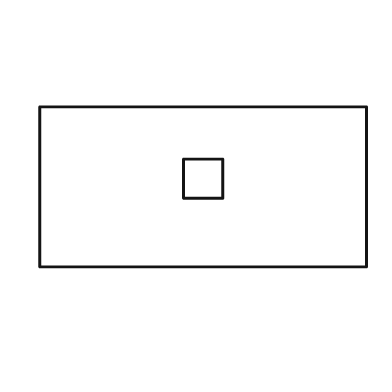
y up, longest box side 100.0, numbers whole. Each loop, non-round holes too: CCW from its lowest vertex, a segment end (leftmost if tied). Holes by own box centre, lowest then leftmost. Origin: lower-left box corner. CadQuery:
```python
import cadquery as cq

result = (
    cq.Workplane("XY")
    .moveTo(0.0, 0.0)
    .lineTo(100.0, 0.0)
    .lineTo(100.0, 49.0)
    .lineTo(0.0, 49.0)
    .close()
    .moveTo(44.0, 21.0)
    .lineTo(56.0, 21.0)
    .lineTo(56.0, 33.0)
    .lineTo(44.0, 33.0)
    .close()
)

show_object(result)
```